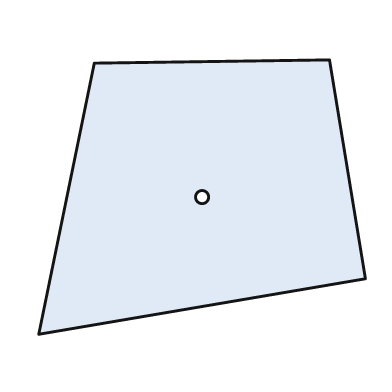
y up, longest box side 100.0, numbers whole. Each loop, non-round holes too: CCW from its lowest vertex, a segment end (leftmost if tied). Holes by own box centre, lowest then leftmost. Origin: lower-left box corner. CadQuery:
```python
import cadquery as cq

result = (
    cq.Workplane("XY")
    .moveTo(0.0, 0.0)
    .lineTo(100.0, 17.0)
    .lineTo(89.0, 84.0)
    .lineTo(17.0, 83.0)
    .close()
    .moveTo(50.0, 42.0)
    .circle(2.0)
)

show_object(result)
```